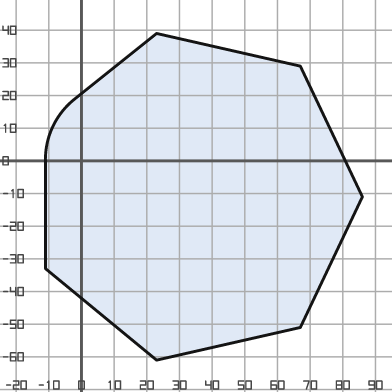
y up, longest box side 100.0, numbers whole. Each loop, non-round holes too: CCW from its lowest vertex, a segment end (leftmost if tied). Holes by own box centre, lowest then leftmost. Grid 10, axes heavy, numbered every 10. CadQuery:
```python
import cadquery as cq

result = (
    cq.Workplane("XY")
    .moveTo(23.0, -61.0)
    .lineTo(67.0, -51.0)
    .lineTo(86.0, -11.0)
    .lineTo(67.0, 29.0)
    .lineTo(23.0, 39.0)
    .lineTo(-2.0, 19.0)
    .threePointArc((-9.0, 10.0), (-11.0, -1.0))
    .lineTo(-11.0, -33.0)
    .close()
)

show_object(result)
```